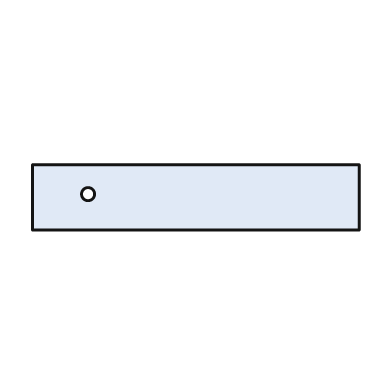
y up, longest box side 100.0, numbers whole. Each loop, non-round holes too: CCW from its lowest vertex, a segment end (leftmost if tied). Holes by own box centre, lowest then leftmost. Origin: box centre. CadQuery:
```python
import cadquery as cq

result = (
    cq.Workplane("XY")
    .moveTo(-50.0, -10.0)
    .lineTo(50.0, -10.0)
    .lineTo(50.0, 10.0)
    .lineTo(-50.0, 10.0)
    .close()
    .moveTo(-33.0, 1.0)
    .circle(2.0)
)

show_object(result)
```